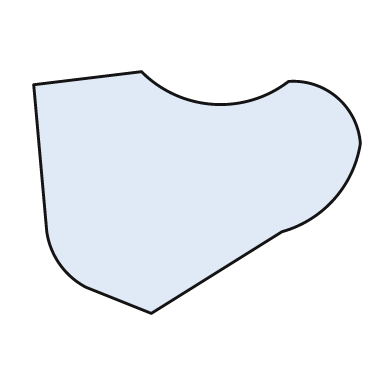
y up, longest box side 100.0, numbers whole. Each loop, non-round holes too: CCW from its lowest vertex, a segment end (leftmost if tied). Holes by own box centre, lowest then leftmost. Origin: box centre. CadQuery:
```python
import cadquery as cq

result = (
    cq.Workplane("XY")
    .moveTo(-14.0, -37.0)
    .lineTo(26.0, -12.0)
    .threePointArc((42.0, -2.0), (50.0, 15.0))
    .threePointArc((43.0, 29.0), (28.0, 34.0))
    .threePointArc((5.0, 27.0), (-17.0, 37.0))
    .lineTo(-50.0, 33.0)
    .lineTo(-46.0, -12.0)
    .threePointArc((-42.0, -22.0), (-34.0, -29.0))
    .close()
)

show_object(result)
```